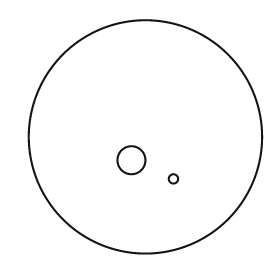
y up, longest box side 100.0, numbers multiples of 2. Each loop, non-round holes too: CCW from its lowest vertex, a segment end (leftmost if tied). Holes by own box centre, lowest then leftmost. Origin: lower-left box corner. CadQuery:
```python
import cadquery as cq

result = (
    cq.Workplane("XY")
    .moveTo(50.0, 50.0)
    .circle(50.0)
    .moveTo(62.0, 32.0)
    .circle(2.0)
    .moveTo(44.0, 40.0)
    .circle(6.0)
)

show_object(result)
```